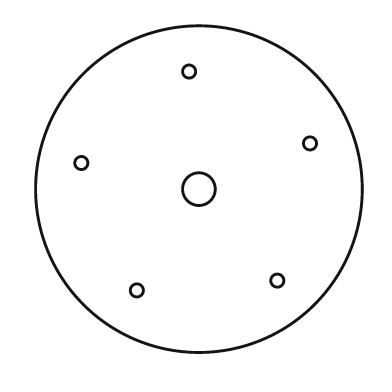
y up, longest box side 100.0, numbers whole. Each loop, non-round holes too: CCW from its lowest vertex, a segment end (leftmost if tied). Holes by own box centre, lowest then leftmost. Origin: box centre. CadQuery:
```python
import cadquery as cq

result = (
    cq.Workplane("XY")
    .moveTo(0.0, 0.0)
    .circle(50.0)
    .moveTo(-19.0, -31.0)
    .circle(2.0)
    .moveTo(24.0, -28.0)
    .circle(2.0)
    .moveTo(0.0, 0.0)
    .circle(5.0)
    .moveTo(-36.0, 8.0)
    .circle(2.0)
    .moveTo(34.0, 14.0)
    .circle(2.0)
    .moveTo(-3.0, 36.0)
    .circle(2.0)
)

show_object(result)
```